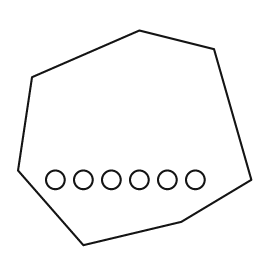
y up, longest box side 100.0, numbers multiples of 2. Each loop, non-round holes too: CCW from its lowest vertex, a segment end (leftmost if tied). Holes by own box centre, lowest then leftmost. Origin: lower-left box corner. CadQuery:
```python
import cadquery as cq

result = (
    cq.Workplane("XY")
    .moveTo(28.0, 0.0)
    .lineTo(70.0, 10.0)
    .lineTo(100.0, 28.0)
    .lineTo(84.0, 84.0)
    .lineTo(52.0, 92.0)
    .lineTo(6.0, 72.0)
    .lineTo(0.0, 32.0)
    .close()
    .moveTo(16.0, 28.0)
    .circle(4.0)
    .moveTo(28.0, 28.0)
    .circle(4.0)
    .moveTo(40.0, 28.0)
    .circle(4.0)
    .moveTo(52.0, 28.0)
    .circle(4.0)
    .moveTo(64.0, 28.0)
    .circle(4.0)
    .moveTo(76.0, 28.0)
    .circle(4.0)
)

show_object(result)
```